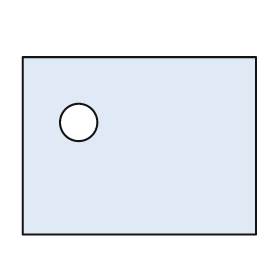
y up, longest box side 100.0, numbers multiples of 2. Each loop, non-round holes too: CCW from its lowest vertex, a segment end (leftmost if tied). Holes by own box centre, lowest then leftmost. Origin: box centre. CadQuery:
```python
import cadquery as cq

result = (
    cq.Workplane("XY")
    .moveTo(-50.0, -38.0)
    .lineTo(50.0, -38.0)
    .lineTo(50.0, 38.0)
    .lineTo(-50.0, 38.0)
    .close()
    .moveTo(-26.0, 10.0)
    .circle(8.0)
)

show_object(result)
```